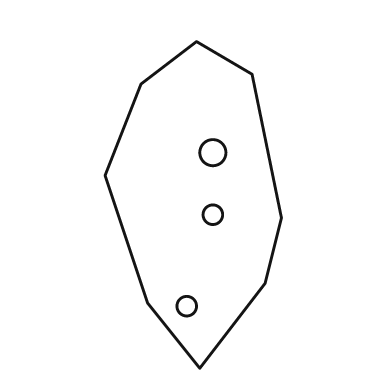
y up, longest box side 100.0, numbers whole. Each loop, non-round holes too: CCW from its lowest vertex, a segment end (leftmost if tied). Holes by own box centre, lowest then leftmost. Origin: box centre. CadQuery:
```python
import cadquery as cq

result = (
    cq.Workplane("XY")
    .moveTo(2.0, -50.0)
    .lineTo(22.0, -24.0)
    .lineTo(27.0, -4.0)
    .lineTo(18.0, 40.0)
    .lineTo(1.0, 50.0)
    .lineTo(-16.0, 37.0)
    .lineTo(-27.0, 9.0)
    .lineTo(-14.0, -30.0)
    .close()
    .moveTo(-2.0, -31.0)
    .circle(3.0)
    .moveTo(6.0, -3.0)
    .circle(3.0)
    .moveTo(6.0, 16.0)
    .circle(4.0)
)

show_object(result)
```